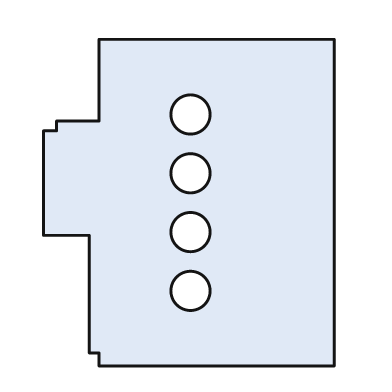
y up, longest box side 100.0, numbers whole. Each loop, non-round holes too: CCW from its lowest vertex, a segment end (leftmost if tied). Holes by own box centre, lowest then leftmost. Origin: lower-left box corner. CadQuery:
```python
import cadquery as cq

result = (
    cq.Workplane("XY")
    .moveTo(17.0, 0.0)
    .lineTo(89.0, 0.0)
    .lineTo(89.0, 100.0)
    .lineTo(17.0, 100.0)
    .lineTo(17.0, 75.0)
    .lineTo(4.0, 75.0)
    .lineTo(4.0, 72.0)
    .lineTo(0.0, 72.0)
    .lineTo(0.0, 40.0)
    .lineTo(14.0, 40.0)
    .lineTo(14.0, 4.0)
    .lineTo(17.0, 4.0)
    .close()
    .moveTo(45.0, 23.0)
    .circle(6.0)
    .moveTo(45.0, 41.0)
    .circle(6.0)
    .moveTo(45.0, 59.0)
    .circle(6.0)
    .moveTo(45.0, 77.0)
    .circle(6.0)
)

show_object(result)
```